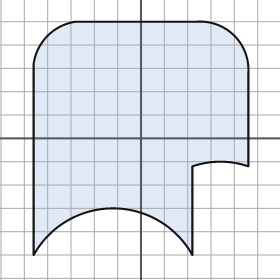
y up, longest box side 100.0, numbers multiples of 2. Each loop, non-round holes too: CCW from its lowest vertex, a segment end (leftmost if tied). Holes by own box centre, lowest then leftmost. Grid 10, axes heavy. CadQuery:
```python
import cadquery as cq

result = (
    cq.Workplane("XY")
    .moveTo(-46.0, -50.0)
    .threePointArc((-12.0, -30.0), (22.0, -50.0))
    .lineTo(22.0, -12.0)
    .threePointArc((34.0, -10.0), (46.0, -12.0))
    .lineTo(46.0, 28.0)
    .threePointArc((40.0, 44.0), (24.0, 50.0))
    .lineTo(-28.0, 50.0)
    .threePointArc((-40.0, 44.0), (-46.0, 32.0))
    .close()
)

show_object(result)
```